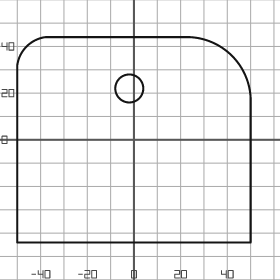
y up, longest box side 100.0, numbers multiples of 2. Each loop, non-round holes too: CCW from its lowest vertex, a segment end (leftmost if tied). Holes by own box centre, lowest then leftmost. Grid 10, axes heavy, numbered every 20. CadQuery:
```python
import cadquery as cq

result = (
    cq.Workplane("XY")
    .moveTo(-50.0, -44.0)
    .lineTo(50.0, -44.0)
    .lineTo(50.0, 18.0)
    .threePointArc((42.0, 36.0), (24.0, 44.0))
    .lineTo(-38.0, 44.0)
    .threePointArc((-46.0, 40.0), (-50.0, 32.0))
    .close()
    .moveTo(-2.0, 22.0)
    .circle(6.0)
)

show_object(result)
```